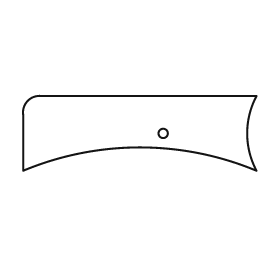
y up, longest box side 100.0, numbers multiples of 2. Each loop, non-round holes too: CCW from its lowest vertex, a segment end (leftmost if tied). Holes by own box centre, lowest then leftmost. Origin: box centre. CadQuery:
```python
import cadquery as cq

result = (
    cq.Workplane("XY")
    .moveTo(-50.0, -16.0)
    .threePointArc((0.0, -6.0), (50.0, -16.0))
    .threePointArc((46.0, 0.0), (50.0, 16.0))
    .lineTo(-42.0, 16.0)
    .threePointArc((-48.0, 14.0), (-50.0, 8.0))
    .close()
    .moveTo(10.0, 0.0)
    .circle(2.0)
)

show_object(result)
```